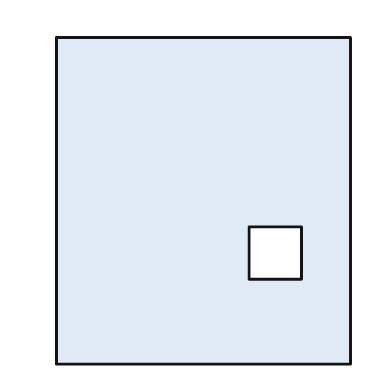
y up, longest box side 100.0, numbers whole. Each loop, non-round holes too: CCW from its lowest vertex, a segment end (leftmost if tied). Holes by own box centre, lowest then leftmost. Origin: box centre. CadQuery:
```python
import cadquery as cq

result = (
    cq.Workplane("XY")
    .moveTo(-45.0, -50.0)
    .lineTo(45.0, -50.0)
    .lineTo(45.0, 50.0)
    .lineTo(-45.0, 50.0)
    .close()
    .moveTo(14.0, -24.0)
    .lineTo(30.0, -24.0)
    .lineTo(30.0, -8.0)
    .lineTo(14.0, -8.0)
    .close()
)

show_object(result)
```